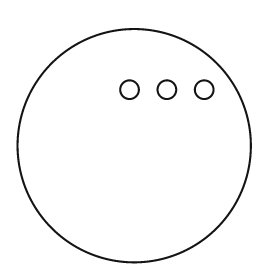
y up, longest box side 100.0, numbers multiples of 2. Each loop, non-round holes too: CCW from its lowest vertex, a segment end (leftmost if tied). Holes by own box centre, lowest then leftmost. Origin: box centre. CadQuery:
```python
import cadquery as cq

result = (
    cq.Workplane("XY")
    .moveTo(0.0, 0.0)
    .circle(50.0)
    .moveTo(-2.0, 24.0)
    .circle(4.0)
    .moveTo(14.0, 24.0)
    .circle(4.0)
    .moveTo(30.0, 24.0)
    .circle(4.0)
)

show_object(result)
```